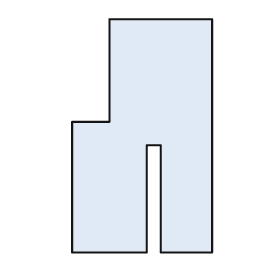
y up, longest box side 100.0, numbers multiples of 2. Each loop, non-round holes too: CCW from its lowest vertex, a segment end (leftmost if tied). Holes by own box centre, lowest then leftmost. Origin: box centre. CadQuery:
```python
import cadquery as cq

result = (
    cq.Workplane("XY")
    .moveTo(-30.0, -50.0)
    .lineTo(2.0, -50.0)
    .lineTo(2.0, -4.0)
    .lineTo(8.0, -4.0)
    .lineTo(8.0, -50.0)
    .lineTo(30.0, -50.0)
    .lineTo(30.0, 50.0)
    .lineTo(-14.0, 50.0)
    .lineTo(-14.0, 6.0)
    .lineTo(-30.0, 6.0)
    .close()
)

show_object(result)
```